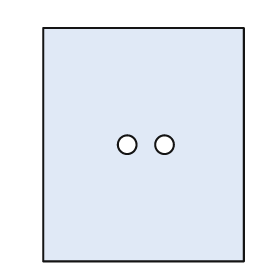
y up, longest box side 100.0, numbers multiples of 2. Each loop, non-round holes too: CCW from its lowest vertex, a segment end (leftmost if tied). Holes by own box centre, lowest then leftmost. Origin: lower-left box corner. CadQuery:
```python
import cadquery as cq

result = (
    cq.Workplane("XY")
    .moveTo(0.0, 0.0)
    .lineTo(86.0, 0.0)
    .lineTo(86.0, 100.0)
    .lineTo(0.0, 100.0)
    .close()
    .moveTo(36.0, 50.0)
    .circle(4.0)
    .moveTo(52.0, 50.0)
    .circle(4.0)
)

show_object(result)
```